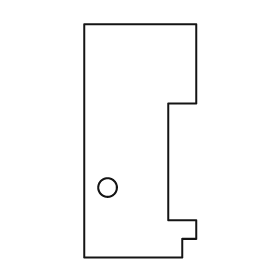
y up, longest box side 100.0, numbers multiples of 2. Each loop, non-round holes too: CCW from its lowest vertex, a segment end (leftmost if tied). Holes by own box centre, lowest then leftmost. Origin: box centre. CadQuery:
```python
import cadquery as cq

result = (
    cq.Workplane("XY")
    .moveTo(-24.0, -50.0)
    .lineTo(18.0, -50.0)
    .lineTo(18.0, -42.0)
    .lineTo(24.0, -42.0)
    .lineTo(24.0, -34.0)
    .lineTo(12.0, -34.0)
    .lineTo(12.0, 16.0)
    .lineTo(24.0, 16.0)
    .lineTo(24.0, 50.0)
    .lineTo(-24.0, 50.0)
    .close()
    .moveTo(-14.0, -20.0)
    .circle(4.0)
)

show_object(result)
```